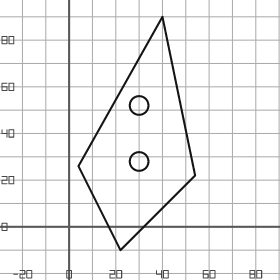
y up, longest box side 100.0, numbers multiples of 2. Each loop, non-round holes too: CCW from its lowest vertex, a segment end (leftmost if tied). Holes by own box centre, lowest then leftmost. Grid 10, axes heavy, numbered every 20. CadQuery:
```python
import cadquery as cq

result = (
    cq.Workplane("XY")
    .moveTo(22.0, -10.0)
    .lineTo(54.0, 22.0)
    .lineTo(40.0, 90.0)
    .lineTo(4.0, 26.0)
    .close()
    .moveTo(30.0, 28.0)
    .circle(4.0)
    .moveTo(30.0, 52.0)
    .circle(4.0)
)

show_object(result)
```